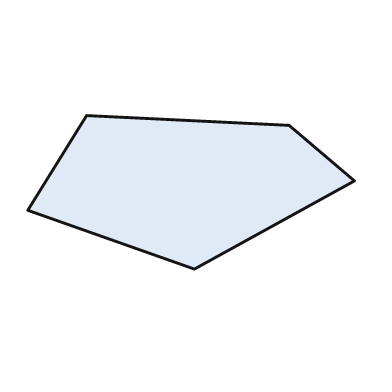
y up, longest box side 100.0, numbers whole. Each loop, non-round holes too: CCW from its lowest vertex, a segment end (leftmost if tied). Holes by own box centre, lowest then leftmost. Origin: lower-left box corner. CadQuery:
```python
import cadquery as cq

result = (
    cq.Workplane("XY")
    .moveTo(51.0, 0.0)
    .lineTo(100.0, 27.0)
    .lineTo(80.0, 44.0)
    .lineTo(18.0, 47.0)
    .lineTo(0.0, 18.0)
    .close()
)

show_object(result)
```